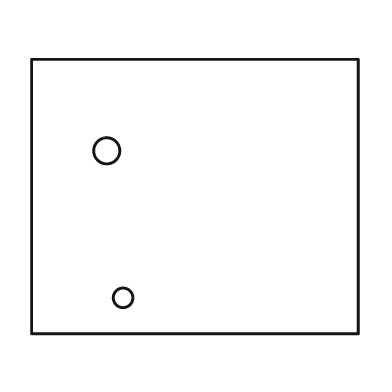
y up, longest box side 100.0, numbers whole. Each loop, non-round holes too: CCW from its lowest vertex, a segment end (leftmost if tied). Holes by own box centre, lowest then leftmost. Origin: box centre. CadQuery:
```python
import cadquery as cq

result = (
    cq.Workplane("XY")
    .moveTo(-50.0, -42.0)
    .lineTo(50.0, -42.0)
    .lineTo(50.0, 42.0)
    .lineTo(-50.0, 42.0)
    .close()
    .moveTo(-22.0, -31.0)
    .circle(3.0)
    .moveTo(-27.0, 14.0)
    .circle(4.0)
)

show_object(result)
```